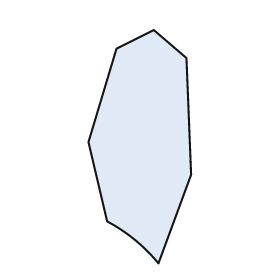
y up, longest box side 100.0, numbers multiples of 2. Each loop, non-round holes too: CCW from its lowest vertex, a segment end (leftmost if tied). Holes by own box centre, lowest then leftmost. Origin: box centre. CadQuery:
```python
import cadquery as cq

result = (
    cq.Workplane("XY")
    .moveTo(8.0, -50.0)
    .lineTo(22.0, -12.0)
    .lineTo(20.0, 38.0)
    .lineTo(6.0, 50.0)
    .lineTo(-10.0, 42.0)
    .lineTo(-22.0, 2.0)
    .lineTo(-14.0, -32.0)
    .threePointArc((-2.0, -40.0), (8.0, -50.0))
    .close()
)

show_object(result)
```